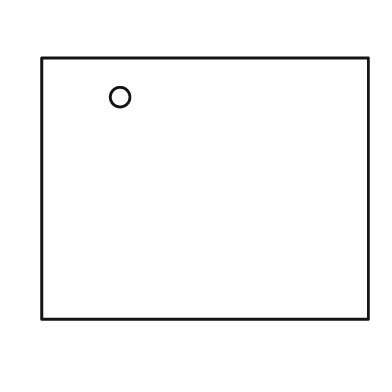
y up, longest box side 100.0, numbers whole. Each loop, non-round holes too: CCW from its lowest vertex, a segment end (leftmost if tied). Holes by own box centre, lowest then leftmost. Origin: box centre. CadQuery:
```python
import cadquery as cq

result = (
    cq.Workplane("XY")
    .moveTo(-50.0, -40.0)
    .lineTo(50.0, -40.0)
    .lineTo(50.0, 40.0)
    .lineTo(-50.0, 40.0)
    .close()
    .moveTo(-26.0, 28.0)
    .circle(3.0)
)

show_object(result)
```